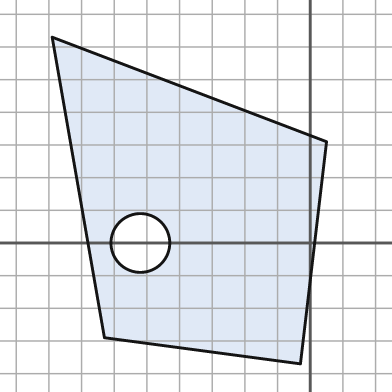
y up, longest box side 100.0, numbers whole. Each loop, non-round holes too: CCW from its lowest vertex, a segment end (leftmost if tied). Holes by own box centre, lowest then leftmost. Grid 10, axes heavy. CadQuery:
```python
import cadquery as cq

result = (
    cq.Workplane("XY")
    .moveTo(-3.0, -37.0)
    .lineTo(5.0, 31.0)
    .lineTo(-79.0, 63.0)
    .lineTo(-63.0, -29.0)
    .close()
    .moveTo(-52.0, 0.0)
    .circle(9.0)
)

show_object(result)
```